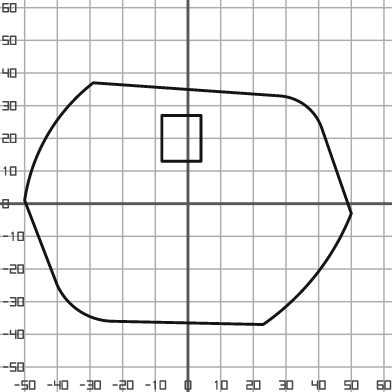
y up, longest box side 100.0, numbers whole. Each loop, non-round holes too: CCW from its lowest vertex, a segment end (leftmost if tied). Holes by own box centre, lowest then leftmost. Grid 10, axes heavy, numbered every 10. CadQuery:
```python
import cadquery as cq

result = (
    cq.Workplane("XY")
    .moveTo(23.0, -37.0)
    .threePointArc((39.0, -22.0), (50.0, -3.0))
    .lineTo(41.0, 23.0)
    .threePointArc((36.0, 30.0), (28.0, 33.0))
    .lineTo(-29.0, 37.0)
    .threePointArc((-43.0, 21.0), (-50.0, 1.0))
    .lineTo(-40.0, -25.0)
    .threePointArc((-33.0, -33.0), (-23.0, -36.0))
    .close()
    .moveTo(-8.0, 13.0)
    .lineTo(4.0, 13.0)
    .lineTo(4.0, 27.0)
    .lineTo(-8.0, 27.0)
    .close()
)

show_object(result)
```